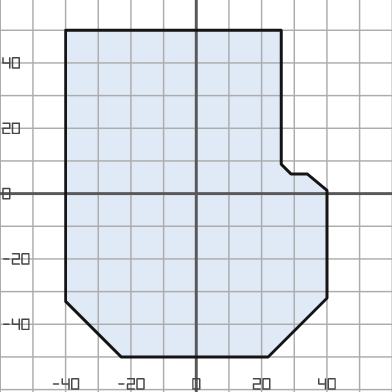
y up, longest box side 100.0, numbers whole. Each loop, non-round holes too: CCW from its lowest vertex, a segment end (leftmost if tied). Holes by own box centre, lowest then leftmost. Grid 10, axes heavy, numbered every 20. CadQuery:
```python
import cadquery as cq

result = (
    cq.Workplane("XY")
    .moveTo(-23.0, -50.0)
    .lineTo(22.0, -50.0)
    .lineTo(40.0, -32.0)
    .lineTo(40.0, 1.0)
    .lineTo(34.0, 6.0)
    .lineTo(29.0, 6.0)
    .lineTo(26.0, 9.0)
    .lineTo(26.0, 50.0)
    .lineTo(-40.0, 50.0)
    .lineTo(-40.0, -33.0)
    .close()
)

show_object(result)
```